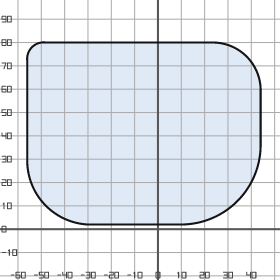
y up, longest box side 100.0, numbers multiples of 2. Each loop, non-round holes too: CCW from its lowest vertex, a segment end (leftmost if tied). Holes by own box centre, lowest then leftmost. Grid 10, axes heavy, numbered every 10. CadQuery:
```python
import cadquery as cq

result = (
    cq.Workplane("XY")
    .moveTo(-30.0, 2.0)
    .lineTo(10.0, 2.0)
    .threePointArc((34.0, 12.0), (44.0, 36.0))
    .lineTo(44.0, 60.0)
    .threePointArc((38.0, 74.0), (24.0, 80.0))
    .lineTo(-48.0, 80.0)
    .threePointArc((-54.0, 78.0), (-56.0, 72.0))
    .lineTo(-56.0, 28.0)
    .threePointArc((-48.0, 10.0), (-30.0, 2.0))
    .close()
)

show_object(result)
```